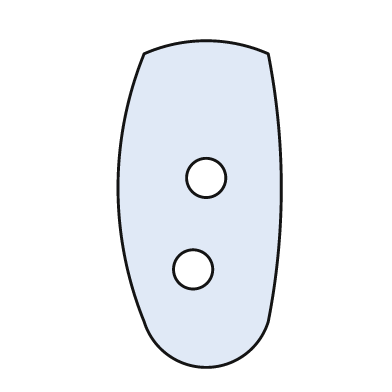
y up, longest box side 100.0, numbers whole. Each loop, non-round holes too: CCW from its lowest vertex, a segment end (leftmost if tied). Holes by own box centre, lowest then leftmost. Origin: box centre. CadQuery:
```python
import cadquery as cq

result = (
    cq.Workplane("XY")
    .moveTo(-17.0, -36.0)
    .threePointArc((2.0, -50.0), (21.0, -36.0))
    .threePointArc((25.0, 5.0), (21.0, 46.0))
    .threePointArc((2.0, 50.0), (-17.0, 46.0))
    .threePointArc((-25.0, 5.0), (-17.0, -36.0))
    .close()
    .moveTo(-2.0, -20.0)
    .circle(6.0)
    .moveTo(2.0, 8.0)
    .circle(6.0)
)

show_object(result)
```